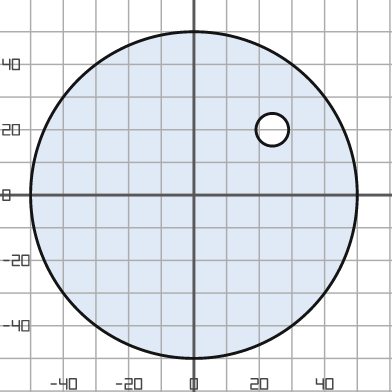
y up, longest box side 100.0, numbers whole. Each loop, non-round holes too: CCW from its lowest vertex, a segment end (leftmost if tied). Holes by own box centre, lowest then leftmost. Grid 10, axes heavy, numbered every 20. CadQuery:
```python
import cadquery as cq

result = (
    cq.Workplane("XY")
    .moveTo(0.0, 0.0)
    .circle(50.0)
    .moveTo(24.0, 20.0)
    .circle(5.0)
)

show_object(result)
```